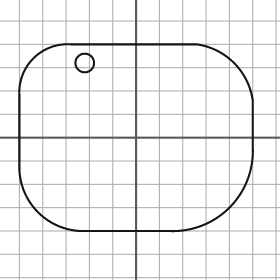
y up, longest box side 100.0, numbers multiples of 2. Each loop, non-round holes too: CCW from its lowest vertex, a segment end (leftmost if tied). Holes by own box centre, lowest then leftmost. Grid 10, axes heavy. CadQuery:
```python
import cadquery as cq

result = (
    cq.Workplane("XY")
    .moveTo(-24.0, -40.0)
    .lineTo(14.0, -40.0)
    .threePointArc((40.0, -30.0), (50.0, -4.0))
    .lineTo(50.0, 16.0)
    .threePointArc((42.0, 32.0), (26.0, 40.0))
    .lineTo(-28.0, 40.0)
    .threePointArc((-44.0, 34.0), (-50.0, 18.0))
    .lineTo(-50.0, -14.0)
    .threePointArc((-42.0, -32.0), (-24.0, -40.0))
    .close()
    .moveTo(-22.0, 32.0)
    .circle(4.0)
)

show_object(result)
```